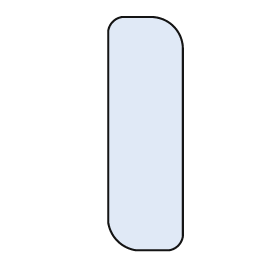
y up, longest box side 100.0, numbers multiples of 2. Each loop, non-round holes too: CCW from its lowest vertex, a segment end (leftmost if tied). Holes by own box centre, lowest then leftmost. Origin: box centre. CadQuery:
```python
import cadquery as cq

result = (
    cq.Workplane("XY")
    .moveTo(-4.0, -50.0)
    .lineTo(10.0, -50.0)
    .threePointArc((14.0, -48.0), (16.0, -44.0))
    .lineTo(16.0, 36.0)
    .threePointArc((12.0, 46.0), (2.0, 50.0))
    .lineTo(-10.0, 50.0)
    .threePointArc((-14.0, 48.0), (-16.0, 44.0))
    .lineTo(-16.0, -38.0)
    .threePointArc((-12.0, -46.0), (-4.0, -50.0))
    .close()
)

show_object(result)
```